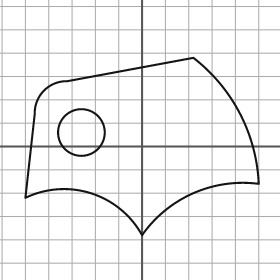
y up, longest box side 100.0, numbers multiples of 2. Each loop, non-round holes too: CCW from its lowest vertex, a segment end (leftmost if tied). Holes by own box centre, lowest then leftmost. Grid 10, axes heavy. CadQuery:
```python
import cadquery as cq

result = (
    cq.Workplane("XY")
    .moveTo(0.0, -38.0)
    .threePointArc((22.0, -20.0), (50.0, -16.0))
    .threePointArc((42.0, 14.0), (22.0, 38.0))
    .lineTo(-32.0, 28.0)
    .threePointArc((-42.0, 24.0), (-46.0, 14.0))
    .lineTo(-50.0, -22.0)
    .threePointArc((-22.0, -20.0), (0.0, -38.0))
    .close()
    .moveTo(-26.0, 6.0)
    .circle(10.0)
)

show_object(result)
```